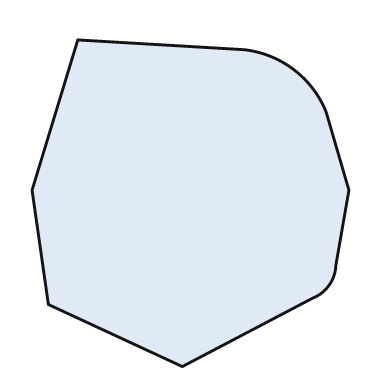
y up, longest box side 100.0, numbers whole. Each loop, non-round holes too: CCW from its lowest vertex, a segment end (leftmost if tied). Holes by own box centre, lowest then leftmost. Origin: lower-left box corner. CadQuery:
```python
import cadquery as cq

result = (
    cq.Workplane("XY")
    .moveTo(46.0, 0.0)
    .lineTo(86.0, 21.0)
    .threePointArc((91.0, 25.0), (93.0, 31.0))
    .lineTo(97.0, 54.0)
    .lineTo(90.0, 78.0)
    .threePointArc((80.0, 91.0), (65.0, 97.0))
    .lineTo(14.0, 100.0)
    .lineTo(0.0, 54.0)
    .lineTo(5.0, 19.0)
    .close()
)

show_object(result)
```